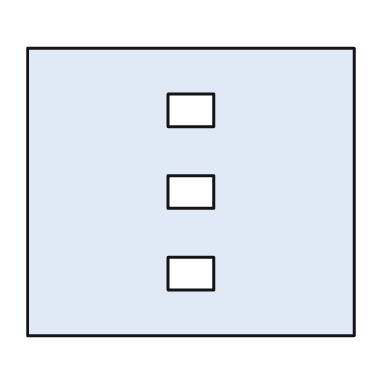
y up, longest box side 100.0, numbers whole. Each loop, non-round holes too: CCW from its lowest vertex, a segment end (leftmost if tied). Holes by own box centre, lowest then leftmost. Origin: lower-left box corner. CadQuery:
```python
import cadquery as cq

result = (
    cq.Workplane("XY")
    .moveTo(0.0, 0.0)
    .lineTo(100.0, 0.0)
    .lineTo(100.0, 88.0)
    .lineTo(0.0, 88.0)
    .close()
    .moveTo(43.0, 14.0)
    .lineTo(57.0, 14.0)
    .lineTo(57.0, 24.0)
    .lineTo(43.0, 24.0)
    .close()
    .moveTo(43.0, 39.0)
    .lineTo(57.0, 39.0)
    .lineTo(57.0, 49.0)
    .lineTo(43.0, 49.0)
    .close()
    .moveTo(43.0, 64.0)
    .lineTo(57.0, 64.0)
    .lineTo(57.0, 74.0)
    .lineTo(43.0, 74.0)
    .close()
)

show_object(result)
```